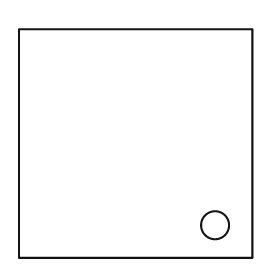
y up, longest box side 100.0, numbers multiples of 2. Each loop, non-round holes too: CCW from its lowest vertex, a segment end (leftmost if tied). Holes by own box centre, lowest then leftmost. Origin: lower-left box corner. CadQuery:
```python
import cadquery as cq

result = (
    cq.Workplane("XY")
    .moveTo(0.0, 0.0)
    .lineTo(100.0, 0.0)
    .lineTo(100.0, 98.0)
    .lineTo(0.0, 98.0)
    .close()
    .moveTo(84.0, 14.0)
    .circle(6.0)
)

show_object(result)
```